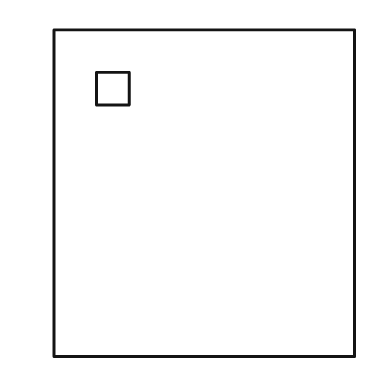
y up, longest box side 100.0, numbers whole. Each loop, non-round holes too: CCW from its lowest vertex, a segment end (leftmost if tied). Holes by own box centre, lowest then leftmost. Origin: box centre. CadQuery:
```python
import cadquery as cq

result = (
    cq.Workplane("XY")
    .moveTo(-46.0, -50.0)
    .lineTo(46.0, -50.0)
    .lineTo(46.0, 50.0)
    .lineTo(-46.0, 50.0)
    .close()
    .moveTo(-33.0, 27.0)
    .lineTo(-23.0, 27.0)
    .lineTo(-23.0, 37.0)
    .lineTo(-33.0, 37.0)
    .close()
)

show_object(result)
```